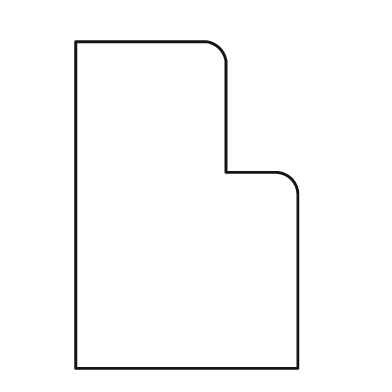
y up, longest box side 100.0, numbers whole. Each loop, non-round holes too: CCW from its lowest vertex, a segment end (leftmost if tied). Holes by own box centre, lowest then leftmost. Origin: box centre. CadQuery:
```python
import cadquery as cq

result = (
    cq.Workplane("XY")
    .moveTo(-34.0, -50.0)
    .lineTo(34.0, -50.0)
    .lineTo(34.0, 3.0)
    .threePointArc((32.0, 8.0), (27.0, 10.0))
    .lineTo(12.0, 10.0)
    .lineTo(12.0, 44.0)
    .threePointArc((10.0, 48.0), (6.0, 50.0))
    .lineTo(-34.0, 50.0)
    .close()
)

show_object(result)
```